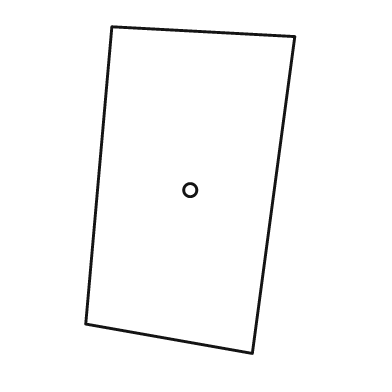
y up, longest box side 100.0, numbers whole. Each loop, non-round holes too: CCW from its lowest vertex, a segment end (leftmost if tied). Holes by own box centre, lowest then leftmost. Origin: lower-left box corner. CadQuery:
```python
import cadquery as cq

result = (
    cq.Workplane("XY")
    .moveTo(51.0, 0.0)
    .lineTo(64.0, 97.0)
    .lineTo(8.0, 100.0)
    .lineTo(0.0, 9.0)
    .close()
    .moveTo(32.0, 50.0)
    .circle(2.0)
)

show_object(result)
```